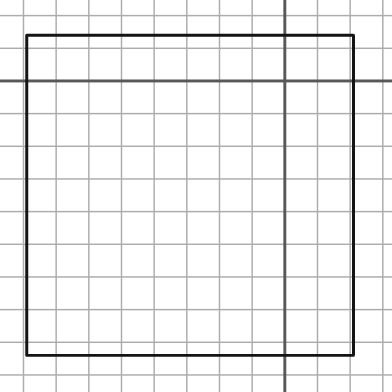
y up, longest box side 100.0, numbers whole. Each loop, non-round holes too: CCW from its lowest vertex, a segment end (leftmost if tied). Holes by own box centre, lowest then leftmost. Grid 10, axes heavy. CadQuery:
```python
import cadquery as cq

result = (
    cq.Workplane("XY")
    .moveTo(-79.0, -84.0)
    .lineTo(21.0, -84.0)
    .lineTo(21.0, 14.0)
    .lineTo(-79.0, 14.0)
    .close()
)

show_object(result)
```